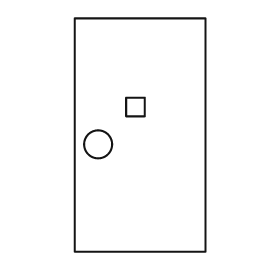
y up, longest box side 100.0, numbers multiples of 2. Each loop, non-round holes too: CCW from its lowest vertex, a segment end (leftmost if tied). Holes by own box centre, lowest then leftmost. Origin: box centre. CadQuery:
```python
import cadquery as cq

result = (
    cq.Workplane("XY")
    .moveTo(-28.0, -50.0)
    .lineTo(28.0, -50.0)
    .lineTo(28.0, 50.0)
    .lineTo(-28.0, 50.0)
    .close()
    .moveTo(-18.0, -4.0)
    .circle(6.0)
    .moveTo(-6.0, 8.0)
    .lineTo(2.0, 8.0)
    .lineTo(2.0, 16.0)
    .lineTo(-6.0, 16.0)
    .close()
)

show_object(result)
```